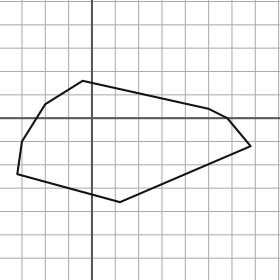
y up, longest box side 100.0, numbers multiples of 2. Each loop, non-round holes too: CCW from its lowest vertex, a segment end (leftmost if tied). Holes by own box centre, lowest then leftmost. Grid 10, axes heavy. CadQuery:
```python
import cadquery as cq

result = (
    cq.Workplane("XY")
    .moveTo(12.0, -36.0)
    .lineTo(68.0, -12.0)
    .lineTo(58.0, 0.0)
    .lineTo(50.0, 4.0)
    .lineTo(-4.0, 16.0)
    .lineTo(-20.0, 6.0)
    .lineTo(-30.0, -10.0)
    .lineTo(-32.0, -24.0)
    .close()
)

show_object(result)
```